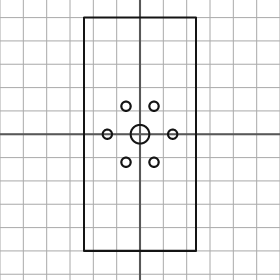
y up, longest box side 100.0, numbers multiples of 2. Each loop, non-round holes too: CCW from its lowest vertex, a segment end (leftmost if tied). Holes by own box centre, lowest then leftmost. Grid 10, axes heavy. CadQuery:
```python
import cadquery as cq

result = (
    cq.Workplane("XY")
    .moveTo(-24.0, -50.0)
    .lineTo(24.0, -50.0)
    .lineTo(24.0, 50.0)
    .lineTo(-24.0, 50.0)
    .close()
    .moveTo(-6.0, -12.0)
    .circle(2.0)
    .moveTo(6.0, -12.0)
    .circle(2.0)
    .moveTo(-14.0, 0.0)
    .circle(2.0)
    .moveTo(0.0, 0.0)
    .circle(4.0)
    .moveTo(14.0, 0.0)
    .circle(2.0)
    .moveTo(-6.0, 12.0)
    .circle(2.0)
    .moveTo(6.0, 12.0)
    .circle(2.0)
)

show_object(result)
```